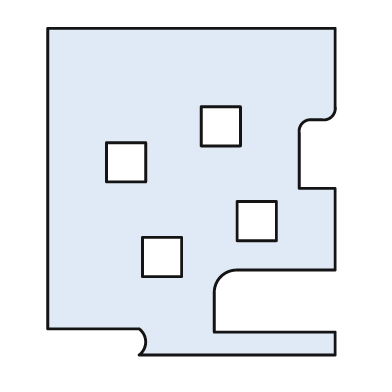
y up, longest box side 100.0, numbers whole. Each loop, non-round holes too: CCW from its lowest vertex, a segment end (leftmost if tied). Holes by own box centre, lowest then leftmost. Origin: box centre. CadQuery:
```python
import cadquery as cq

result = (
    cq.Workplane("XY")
    .moveTo(-16.0, -50.0)
    .lineTo(44.0, -50.0)
    .lineTo(44.0, -43.0)
    .lineTo(7.0, -43.0)
    .lineTo(7.0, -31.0)
    .threePointArc((9.0, -26.0), (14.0, -24.0))
    .lineTo(44.0, -24.0)
    .lineTo(44.0, 1.0)
    .lineTo(33.0, 1.0)
    .lineTo(33.0, 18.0)
    .threePointArc((34.0, 21.0), (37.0, 22.0))
    .lineTo(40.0, 22.0)
    .threePointArc((43.0, 23.0), (44.0, 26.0))
    .lineTo(44.0, 50.0)
    .lineTo(-44.0, 50.0)
    .lineTo(-44.0, -42.0)
    .lineTo(-16.0, -42.0)
    .threePointArc((-14.0, -46.0), (-16.0, -50.0))
    .close()
    .moveTo(-15.0, -26.0)
    .lineTo(-3.0, -26.0)
    .lineTo(-3.0, -14.0)
    .lineTo(-15.0, -14.0)
    .close()
    .moveTo(14.0, -15.0)
    .lineTo(26.0, -15.0)
    .lineTo(26.0, -3.0)
    .lineTo(14.0, -3.0)
    .close()
    .moveTo(-26.0, 3.0)
    .lineTo(-14.0, 3.0)
    .lineTo(-14.0, 15.0)
    .lineTo(-26.0, 15.0)
    .close()
    .moveTo(3.0, 14.0)
    .lineTo(15.0, 14.0)
    .lineTo(15.0, 26.0)
    .lineTo(3.0, 26.0)
    .close()
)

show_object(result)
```